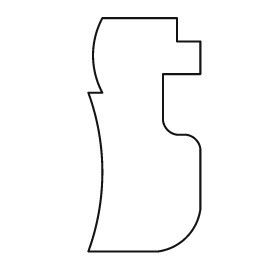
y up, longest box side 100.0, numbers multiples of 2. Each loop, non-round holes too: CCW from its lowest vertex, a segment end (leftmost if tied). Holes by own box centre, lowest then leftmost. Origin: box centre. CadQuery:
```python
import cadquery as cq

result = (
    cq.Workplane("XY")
    .moveTo(-24.0, -50.0)
    .lineTo(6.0, -50.0)
    .threePointArc((18.0, -44.0), (24.0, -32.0))
    .lineTo(24.0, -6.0)
    .threePointArc((22.0, -2.0), (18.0, 0.0))
    .lineTo(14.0, 0.0)
    .threePointArc((10.0, 2.0), (8.0, 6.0))
    .lineTo(8.0, 26.0)
    .lineTo(24.0, 26.0)
    .lineTo(24.0, 40.0)
    .lineTo(14.0, 40.0)
    .lineTo(14.0, 50.0)
    .lineTo(-18.0, 50.0)
    .threePointArc((-22.0, 34.0), (-18.0, 18.0))
    .lineTo(-24.0, 18.0)
    .threePointArc((-18.0, -16.0), (-24.0, -50.0))
    .close()
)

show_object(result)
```